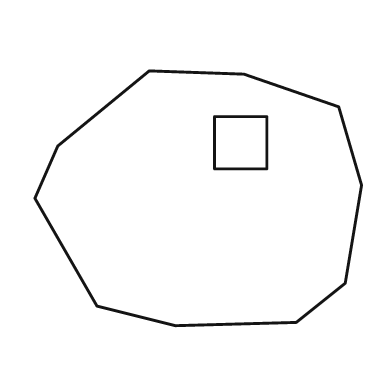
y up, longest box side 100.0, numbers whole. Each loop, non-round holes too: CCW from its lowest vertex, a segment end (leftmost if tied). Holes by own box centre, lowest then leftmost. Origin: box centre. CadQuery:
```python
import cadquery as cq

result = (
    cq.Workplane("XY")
    .moveTo(-7.0, -39.0)
    .lineTo(30.0, -38.0)
    .lineTo(45.0, -26.0)
    .lineTo(50.0, 4.0)
    .lineTo(43.0, 28.0)
    .lineTo(14.0, 38.0)
    .lineTo(-15.0, 39.0)
    .lineTo(-43.0, 16.0)
    .lineTo(-50.0, 0.0)
    .lineTo(-31.0, -33.0)
    .close()
    .moveTo(5.0, 9.0)
    .lineTo(21.0, 9.0)
    .lineTo(21.0, 25.0)
    .lineTo(5.0, 25.0)
    .close()
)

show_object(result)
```